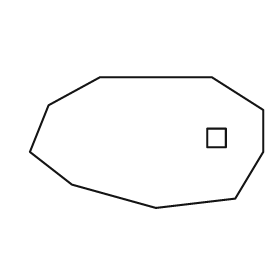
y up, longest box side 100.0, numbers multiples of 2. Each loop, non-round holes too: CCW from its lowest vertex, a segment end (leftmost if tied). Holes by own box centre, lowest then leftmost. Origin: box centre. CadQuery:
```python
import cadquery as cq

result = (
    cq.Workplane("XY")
    .moveTo(4.0, -28.0)
    .lineTo(38.0, -24.0)
    .lineTo(50.0, -4.0)
    .lineTo(50.0, 14.0)
    .lineTo(28.0, 28.0)
    .lineTo(-20.0, 28.0)
    .lineTo(-42.0, 16.0)
    .lineTo(-50.0, -4.0)
    .lineTo(-32.0, -18.0)
    .close()
    .moveTo(26.0, -2.0)
    .lineTo(34.0, -2.0)
    .lineTo(34.0, 6.0)
    .lineTo(26.0, 6.0)
    .close()
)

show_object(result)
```